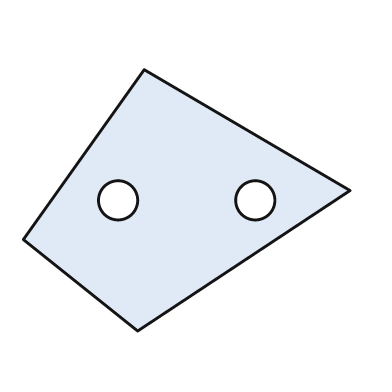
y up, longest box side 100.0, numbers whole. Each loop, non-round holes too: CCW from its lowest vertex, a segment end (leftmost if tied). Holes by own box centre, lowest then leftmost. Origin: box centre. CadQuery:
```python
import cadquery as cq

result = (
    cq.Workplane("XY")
    .moveTo(-15.0, -40.0)
    .lineTo(50.0, 3.0)
    .lineTo(-13.0, 40.0)
    .lineTo(-50.0, -12.0)
    .close()
    .moveTo(-21.0, 0.0)
    .circle(6.0)
    .moveTo(21.0, 0.0)
    .circle(6.0)
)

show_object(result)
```